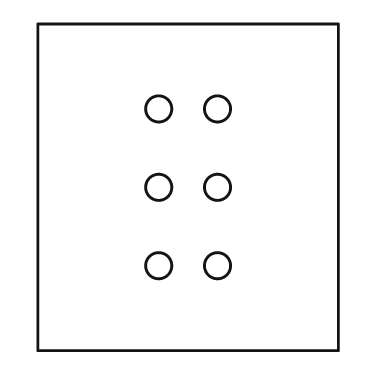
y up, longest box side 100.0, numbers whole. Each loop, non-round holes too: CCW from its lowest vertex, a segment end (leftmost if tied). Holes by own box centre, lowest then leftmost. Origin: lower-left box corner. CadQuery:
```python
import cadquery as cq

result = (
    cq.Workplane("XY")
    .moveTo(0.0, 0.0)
    .lineTo(92.0, 0.0)
    .lineTo(92.0, 100.0)
    .lineTo(0.0, 100.0)
    .close()
    .moveTo(37.0, 26.0)
    .circle(4.0)
    .moveTo(55.0, 26.0)
    .circle(4.0)
    .moveTo(37.0, 50.0)
    .circle(4.0)
    .moveTo(55.0, 50.0)
    .circle(4.0)
    .moveTo(37.0, 74.0)
    .circle(4.0)
    .moveTo(55.0, 74.0)
    .circle(4.0)
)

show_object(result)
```